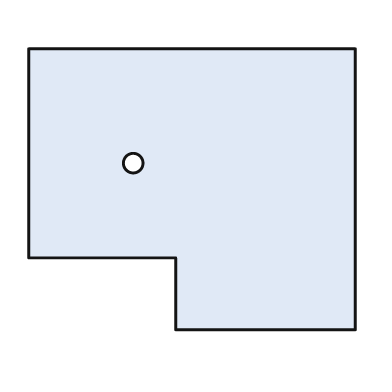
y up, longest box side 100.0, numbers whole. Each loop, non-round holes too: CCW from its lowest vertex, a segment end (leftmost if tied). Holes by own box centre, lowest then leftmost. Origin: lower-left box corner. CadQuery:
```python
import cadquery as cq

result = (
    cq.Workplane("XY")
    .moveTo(45.0, 0.0)
    .lineTo(100.0, 0.0)
    .lineTo(100.0, 86.0)
    .lineTo(0.0, 86.0)
    .lineTo(0.0, 22.0)
    .lineTo(45.0, 22.0)
    .close()
    .moveTo(32.0, 51.0)
    .circle(3.0)
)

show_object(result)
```